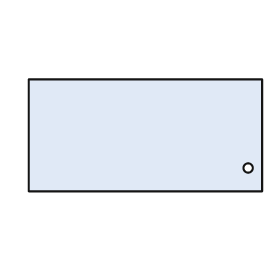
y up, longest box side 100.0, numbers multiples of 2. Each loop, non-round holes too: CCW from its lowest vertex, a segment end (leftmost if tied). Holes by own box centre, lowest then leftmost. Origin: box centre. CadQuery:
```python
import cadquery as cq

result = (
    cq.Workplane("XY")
    .moveTo(-50.0, -24.0)
    .lineTo(50.0, -24.0)
    .lineTo(50.0, 24.0)
    .lineTo(-50.0, 24.0)
    .close()
    .moveTo(44.0, -14.0)
    .circle(2.0)
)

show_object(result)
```